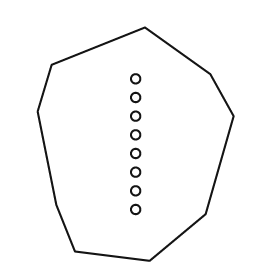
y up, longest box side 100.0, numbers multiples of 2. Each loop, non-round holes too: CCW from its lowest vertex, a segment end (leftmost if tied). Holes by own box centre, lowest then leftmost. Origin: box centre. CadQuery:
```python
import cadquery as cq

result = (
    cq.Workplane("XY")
    .moveTo(6.0, -50.0)
    .lineTo(30.0, -30.0)
    .lineTo(42.0, 12.0)
    .lineTo(32.0, 30.0)
    .lineTo(4.0, 50.0)
    .lineTo(-36.0, 34.0)
    .lineTo(-42.0, 14.0)
    .lineTo(-34.0, -26.0)
    .lineTo(-26.0, -46.0)
    .close()
    .moveTo(0.0, -28.0)
    .circle(2.0)
    .moveTo(0.0, -20.0)
    .circle(2.0)
    .moveTo(0.0, -12.0)
    .circle(2.0)
    .moveTo(0.0, -4.0)
    .circle(2.0)
    .moveTo(0.0, 4.0)
    .circle(2.0)
    .moveTo(0.0, 12.0)
    .circle(2.0)
    .moveTo(0.0, 20.0)
    .circle(2.0)
    .moveTo(0.0, 28.0)
    .circle(2.0)
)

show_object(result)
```